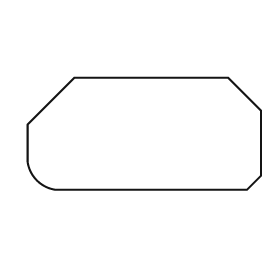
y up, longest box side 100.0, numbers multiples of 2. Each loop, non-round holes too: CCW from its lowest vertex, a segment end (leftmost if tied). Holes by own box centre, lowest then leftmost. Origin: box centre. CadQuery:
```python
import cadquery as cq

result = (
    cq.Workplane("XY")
    .moveTo(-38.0, -24.0)
    .lineTo(44.0, -24.0)
    .lineTo(50.0, -18.0)
    .lineTo(50.0, 10.0)
    .lineTo(36.0, 24.0)
    .lineTo(-30.0, 24.0)
    .lineTo(-50.0, 4.0)
    .lineTo(-50.0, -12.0)
    .threePointArc((-46.0, -20.0), (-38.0, -24.0))
    .close()
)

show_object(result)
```